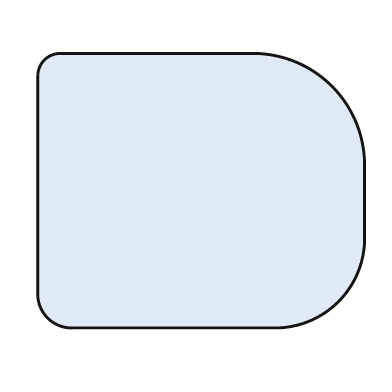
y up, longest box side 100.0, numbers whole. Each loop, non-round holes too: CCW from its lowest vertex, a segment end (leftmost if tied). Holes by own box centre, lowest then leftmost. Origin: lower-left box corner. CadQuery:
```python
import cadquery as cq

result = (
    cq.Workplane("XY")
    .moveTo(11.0, 0.0)
    .lineTo(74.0, 0.0)
    .threePointArc((92.0, 8.0), (100.0, 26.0))
    .lineTo(100.0, 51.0)
    .threePointArc((90.0, 74.0), (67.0, 84.0))
    .lineTo(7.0, 84.0)
    .threePointArc((2.0, 82.0), (0.0, 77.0))
    .lineTo(0.0, 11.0)
    .threePointArc((3.0, 3.0), (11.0, 0.0))
    .close()
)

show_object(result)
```